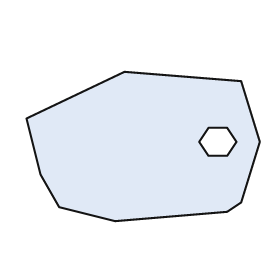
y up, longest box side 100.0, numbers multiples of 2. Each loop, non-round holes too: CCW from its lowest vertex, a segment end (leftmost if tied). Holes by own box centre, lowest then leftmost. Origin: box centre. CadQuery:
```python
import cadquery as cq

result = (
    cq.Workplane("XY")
    .moveTo(-12.0, -32.0)
    .lineTo(36.0, -28.0)
    .lineTo(42.0, -24.0)
    .lineTo(50.0, 2.0)
    .lineTo(42.0, 28.0)
    .lineTo(-8.0, 32.0)
    .lineTo(-50.0, 12.0)
    .lineTo(-44.0, -12.0)
    .lineTo(-36.0, -26.0)
    .close()
    .moveTo(28.0, -4.0)
    .lineTo(36.0, -4.0)
    .lineTo(40.0, 2.0)
    .lineTo(36.0, 8.0)
    .lineTo(28.0, 8.0)
    .lineTo(24.0, 2.0)
    .close()
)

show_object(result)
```